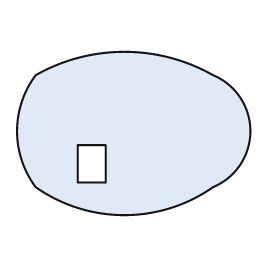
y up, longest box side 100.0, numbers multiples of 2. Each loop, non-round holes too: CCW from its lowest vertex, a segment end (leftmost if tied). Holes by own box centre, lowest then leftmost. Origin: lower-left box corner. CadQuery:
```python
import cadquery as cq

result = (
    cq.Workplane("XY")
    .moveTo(8.0, 12.0)
    .threePointArc((46.0, 0.0), (84.0, 12.0))
    .threePointArc((100.0, 36.0), (84.0, 60.0))
    .threePointArc((46.0, 70.0), (8.0, 60.0))
    .threePointArc((0.0, 36.0), (8.0, 12.0))
    .close()
    .moveTo(26.0, 14.0)
    .lineTo(38.0, 14.0)
    .lineTo(38.0, 30.0)
    .lineTo(26.0, 30.0)
    .close()
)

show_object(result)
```